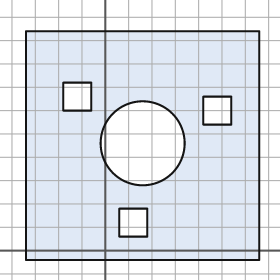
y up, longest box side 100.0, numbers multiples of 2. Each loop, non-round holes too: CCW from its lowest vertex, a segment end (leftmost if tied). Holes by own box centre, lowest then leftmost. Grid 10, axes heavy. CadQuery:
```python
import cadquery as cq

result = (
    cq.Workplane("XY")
    .moveTo(-34.0, -4.0)
    .lineTo(66.0, -4.0)
    .lineTo(66.0, 94.0)
    .lineTo(-34.0, 94.0)
    .close()
    .moveTo(6.0, 6.0)
    .lineTo(18.0, 6.0)
    .lineTo(18.0, 18.0)
    .lineTo(6.0, 18.0)
    .close()
    .moveTo(16.0, 46.0)
    .circle(18.0)
    .moveTo(42.0, 54.0)
    .lineTo(54.0, 54.0)
    .lineTo(54.0, 66.0)
    .lineTo(42.0, 66.0)
    .close()
    .moveTo(-18.0, 60.0)
    .lineTo(-6.0, 60.0)
    .lineTo(-6.0, 72.0)
    .lineTo(-18.0, 72.0)
    .close()
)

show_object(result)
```